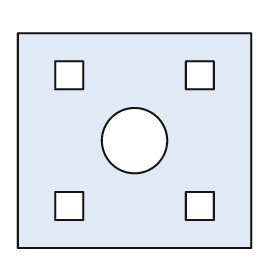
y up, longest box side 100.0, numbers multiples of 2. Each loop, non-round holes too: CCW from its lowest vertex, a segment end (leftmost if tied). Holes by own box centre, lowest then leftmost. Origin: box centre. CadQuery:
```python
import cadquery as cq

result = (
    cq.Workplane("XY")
    .moveTo(-50.0, -46.0)
    .lineTo(50.0, -46.0)
    .lineTo(50.0, 46.0)
    .lineTo(-50.0, 46.0)
    .close()
    .moveTo(-34.0, -34.0)
    .lineTo(-22.0, -34.0)
    .lineTo(-22.0, -22.0)
    .lineTo(-34.0, -22.0)
    .close()
    .moveTo(22.0, -34.0)
    .lineTo(34.0, -34.0)
    .lineTo(34.0, -22.0)
    .lineTo(22.0, -22.0)
    .close()
    .moveTo(0.0, 0.0)
    .circle(14.0)
    .moveTo(-34.0, 22.0)
    .lineTo(-22.0, 22.0)
    .lineTo(-22.0, 34.0)
    .lineTo(-34.0, 34.0)
    .close()
    .moveTo(22.0, 22.0)
    .lineTo(34.0, 22.0)
    .lineTo(34.0, 34.0)
    .lineTo(22.0, 34.0)
    .close()
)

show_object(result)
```